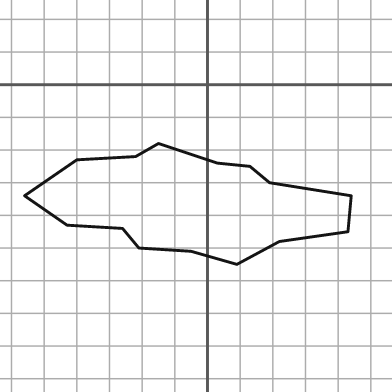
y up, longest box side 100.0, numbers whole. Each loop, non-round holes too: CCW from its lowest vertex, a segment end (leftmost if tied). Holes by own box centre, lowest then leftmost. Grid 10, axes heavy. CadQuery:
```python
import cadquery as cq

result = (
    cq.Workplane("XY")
    .moveTo(9.0, -55.0)
    .lineTo(22.0, -48.0)
    .lineTo(43.0, -45.0)
    .lineTo(44.0, -34.0)
    .lineTo(19.0, -30.0)
    .lineTo(13.0, -25.0)
    .lineTo(3.0, -24.0)
    .lineTo(-15.0, -18.0)
    .lineTo(-22.0, -22.0)
    .lineTo(-40.0, -23.0)
    .lineTo(-56.0, -34.0)
    .lineTo(-43.0, -43.0)
    .lineTo(-26.0, -44.0)
    .lineTo(-21.0, -50.0)
    .lineTo(-5.0, -51.0)
    .close()
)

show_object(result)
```